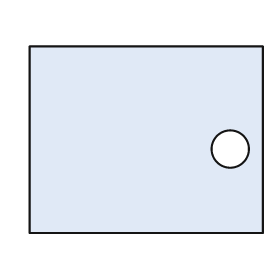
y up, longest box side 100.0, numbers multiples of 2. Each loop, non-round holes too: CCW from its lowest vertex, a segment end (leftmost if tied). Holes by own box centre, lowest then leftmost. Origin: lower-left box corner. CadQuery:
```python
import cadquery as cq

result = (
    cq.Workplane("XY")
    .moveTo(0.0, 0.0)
    .lineTo(100.0, 0.0)
    .lineTo(100.0, 80.0)
    .lineTo(0.0, 80.0)
    .close()
    .moveTo(86.0, 36.0)
    .circle(8.0)
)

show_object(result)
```